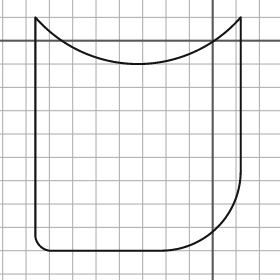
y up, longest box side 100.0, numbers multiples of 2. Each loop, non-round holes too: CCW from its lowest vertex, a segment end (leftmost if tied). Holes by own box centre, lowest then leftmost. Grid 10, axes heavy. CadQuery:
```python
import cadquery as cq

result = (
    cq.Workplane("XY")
    .moveTo(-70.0, -90.0)
    .lineTo(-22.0, -90.0)
    .threePointArc((2.0, -80.0), (12.0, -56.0))
    .lineTo(12.0, 10.0)
    .threePointArc((-32.0, -10.0), (-76.0, 10.0))
    .lineTo(-76.0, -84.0)
    .threePointArc((-74.0, -88.0), (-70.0, -90.0))
    .close()
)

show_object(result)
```